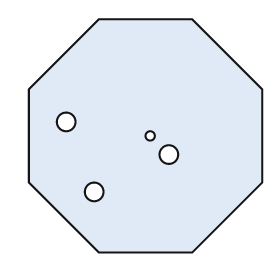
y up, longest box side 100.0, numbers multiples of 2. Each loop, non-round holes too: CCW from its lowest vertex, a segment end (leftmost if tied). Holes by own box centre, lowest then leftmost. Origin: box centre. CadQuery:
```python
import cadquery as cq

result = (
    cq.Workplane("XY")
    .moveTo(-20.0, -50.0)
    .lineTo(20.0, -50.0)
    .lineTo(50.0, -20.0)
    .lineTo(50.0, 20.0)
    .lineTo(20.0, 50.0)
    .lineTo(-20.0, 50.0)
    .lineTo(-50.0, 20.0)
    .lineTo(-50.0, -20.0)
    .close()
    .moveTo(-22.0, -24.0)
    .circle(4.0)
    .moveTo(10.0, -8.0)
    .circle(4.0)
    .moveTo(2.0, 0.0)
    .circle(2.0)
    .moveTo(-34.0, 6.0)
    .circle(4.0)
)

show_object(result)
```